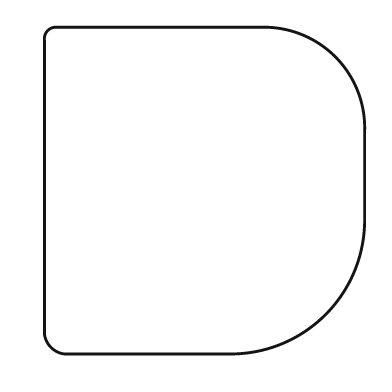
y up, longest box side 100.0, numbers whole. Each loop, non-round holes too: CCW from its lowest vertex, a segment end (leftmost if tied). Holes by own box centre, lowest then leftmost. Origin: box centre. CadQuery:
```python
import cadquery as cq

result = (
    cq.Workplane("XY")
    .moveTo(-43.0, -50.0)
    .lineTo(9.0, -50.0)
    .threePointArc((37.0, -38.0), (49.0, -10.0))
    .lineTo(49.0, 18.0)
    .threePointArc((40.0, 41.0), (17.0, 50.0))
    .lineTo(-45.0, 50.0)
    .threePointArc((-48.0, 49.0), (-49.0, 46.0))
    .lineTo(-49.0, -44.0)
    .threePointArc((-47.0, -48.0), (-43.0, -50.0))
    .close()
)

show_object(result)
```